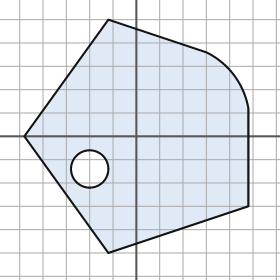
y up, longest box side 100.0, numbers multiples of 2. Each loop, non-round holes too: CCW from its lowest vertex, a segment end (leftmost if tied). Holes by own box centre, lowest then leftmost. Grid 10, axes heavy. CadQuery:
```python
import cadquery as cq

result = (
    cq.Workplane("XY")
    .moveTo(-12.0, -50.0)
    .lineTo(48.0, -30.0)
    .lineTo(48.0, 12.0)
    .threePointArc((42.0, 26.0), (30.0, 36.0))
    .lineTo(-12.0, 50.0)
    .lineTo(-48.0, 0.0)
    .close()
    .moveTo(-20.0, -14.0)
    .circle(8.0)
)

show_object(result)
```